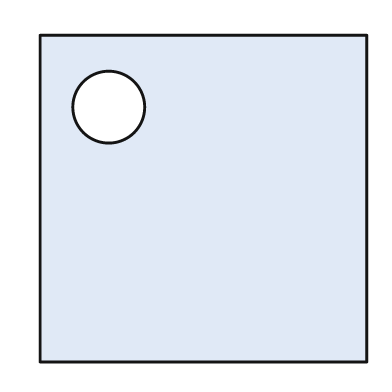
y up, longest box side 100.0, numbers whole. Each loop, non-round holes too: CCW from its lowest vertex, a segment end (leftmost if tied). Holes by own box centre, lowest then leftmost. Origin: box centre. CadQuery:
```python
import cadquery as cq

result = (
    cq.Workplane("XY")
    .moveTo(-50.0, -50.0)
    .lineTo(50.0, -50.0)
    .lineTo(50.0, 50.0)
    .lineTo(-50.0, 50.0)
    .close()
    .moveTo(-29.0, 28.0)
    .circle(11.0)
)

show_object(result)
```